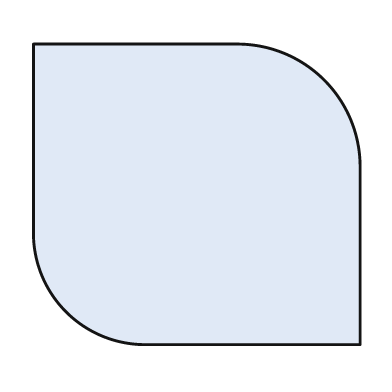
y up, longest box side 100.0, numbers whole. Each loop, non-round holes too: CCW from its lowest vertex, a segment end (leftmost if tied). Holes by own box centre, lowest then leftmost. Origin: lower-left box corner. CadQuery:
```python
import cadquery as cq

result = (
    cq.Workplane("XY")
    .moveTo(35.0, 0.0)
    .lineTo(100.0, 0.0)
    .lineTo(100.0, 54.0)
    .threePointArc((89.0, 81.0), (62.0, 92.0))
    .lineTo(0.0, 92.0)
    .lineTo(0.0, 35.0)
    .threePointArc((10.0, 10.0), (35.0, 0.0))
    .close()
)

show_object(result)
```